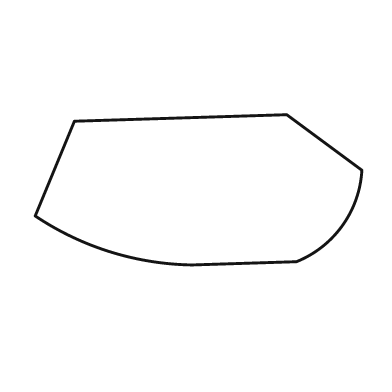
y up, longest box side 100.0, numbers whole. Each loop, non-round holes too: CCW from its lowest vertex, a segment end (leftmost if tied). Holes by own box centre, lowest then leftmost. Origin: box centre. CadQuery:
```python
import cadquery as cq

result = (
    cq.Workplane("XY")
    .moveTo(-2.0, -23.0)
    .lineTo(30.0, -22.0)
    .threePointArc((44.0, -11.0), (50.0, 6.0))
    .lineTo(27.0, 23.0)
    .lineTo(-38.0, 21.0)
    .lineTo(-50.0, -8.0)
    .threePointArc((-27.0, -19.0), (-2.0, -23.0))
    .close()
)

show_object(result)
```